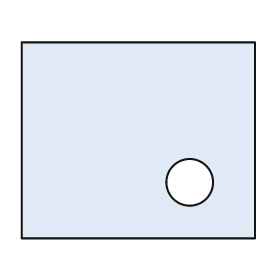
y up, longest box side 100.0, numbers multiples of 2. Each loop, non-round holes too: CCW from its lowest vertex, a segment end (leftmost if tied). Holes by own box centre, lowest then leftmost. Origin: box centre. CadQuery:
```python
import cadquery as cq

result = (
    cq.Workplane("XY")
    .moveTo(-50.0, -42.0)
    .lineTo(50.0, -42.0)
    .lineTo(50.0, 42.0)
    .lineTo(-50.0, 42.0)
    .close()
    .moveTo(22.0, -18.0)
    .circle(10.0)
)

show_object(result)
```